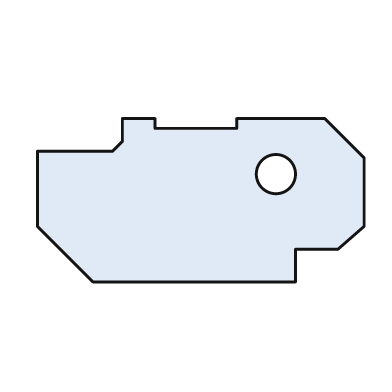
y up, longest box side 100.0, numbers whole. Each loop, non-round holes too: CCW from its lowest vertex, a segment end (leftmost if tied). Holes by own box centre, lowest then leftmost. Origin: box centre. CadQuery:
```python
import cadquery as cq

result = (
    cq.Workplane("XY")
    .moveTo(-33.0, -25.0)
    .lineTo(29.0, -25.0)
    .lineTo(29.0, -15.0)
    .lineTo(42.0, -15.0)
    .lineTo(50.0, -8.0)
    .lineTo(50.0, 13.0)
    .lineTo(38.0, 25.0)
    .lineTo(11.0, 25.0)
    .lineTo(11.0, 22.0)
    .lineTo(-14.0, 22.0)
    .lineTo(-14.0, 25.0)
    .lineTo(-24.0, 25.0)
    .lineTo(-24.0, 18.0)
    .lineTo(-27.0, 15.0)
    .lineTo(-50.0, 15.0)
    .lineTo(-50.0, -8.0)
    .close()
    .moveTo(23.0, 8.0)
    .circle(6.0)
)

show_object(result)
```